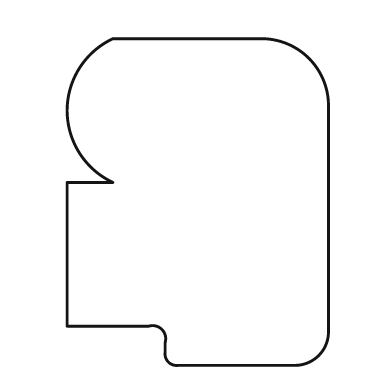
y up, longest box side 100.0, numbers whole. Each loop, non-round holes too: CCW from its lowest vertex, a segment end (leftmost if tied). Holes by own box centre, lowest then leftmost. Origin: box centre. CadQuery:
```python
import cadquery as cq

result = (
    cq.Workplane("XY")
    .moveTo(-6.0, -50.0)
    .lineTo(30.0, -50.0)
    .threePointArc((37.0, -47.0), (40.0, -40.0))
    .lineTo(40.0, 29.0)
    .threePointArc((34.0, 44.0), (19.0, 50.0))
    .lineTo(-26.0, 50.0)
    .threePointArc((-40.0, 28.0), (-26.0, 6.0))
    .lineTo(-40.0, 6.0)
    .lineTo(-40.0, -38.0)
    .lineTo(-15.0, -38.0)
    .threePointArc((-11.0, -39.0), (-10.0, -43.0))
    .lineTo(-10.0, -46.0)
    .threePointArc((-9.0, -49.0), (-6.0, -50.0))
    .close()
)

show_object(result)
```